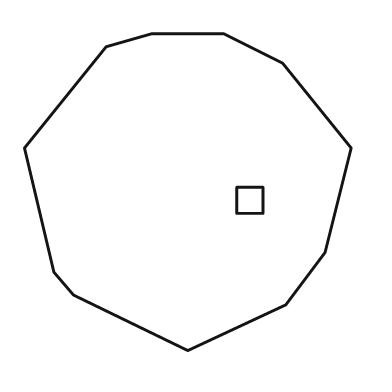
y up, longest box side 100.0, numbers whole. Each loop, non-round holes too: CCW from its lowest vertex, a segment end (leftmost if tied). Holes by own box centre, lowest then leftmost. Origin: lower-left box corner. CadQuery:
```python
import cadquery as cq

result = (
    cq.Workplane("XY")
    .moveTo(50.0, 0.0)
    .lineTo(80.0, 14.0)
    .lineTo(92.0, 30.0)
    .lineTo(100.0, 62.0)
    .lineTo(79.0, 88.0)
    .lineTo(61.0, 97.0)
    .lineTo(39.0, 97.0)
    .lineTo(25.0, 93.0)
    .lineTo(0.0, 62.0)
    .lineTo(9.0, 24.0)
    .lineTo(15.0, 17.0)
    .close()
    .moveTo(65.0, 42.0)
    .lineTo(73.0, 42.0)
    .lineTo(73.0, 50.0)
    .lineTo(65.0, 50.0)
    .close()
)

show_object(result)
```